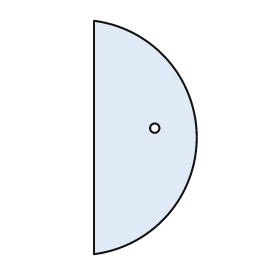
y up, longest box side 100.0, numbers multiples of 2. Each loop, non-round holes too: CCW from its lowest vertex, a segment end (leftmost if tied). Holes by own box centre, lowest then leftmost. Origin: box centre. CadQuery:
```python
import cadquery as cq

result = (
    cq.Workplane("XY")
    .moveTo(-22.0, -50.0)
    .threePointArc((22.0, 0.0), (-22.0, 50.0))
    .close()
    .moveTo(4.0, 4.0)
    .circle(2.0)
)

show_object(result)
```